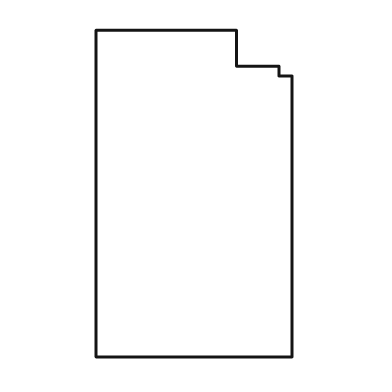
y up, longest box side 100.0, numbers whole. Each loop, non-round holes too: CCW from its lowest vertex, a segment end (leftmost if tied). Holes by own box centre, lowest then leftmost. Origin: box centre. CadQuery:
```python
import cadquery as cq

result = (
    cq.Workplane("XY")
    .moveTo(-30.0, -50.0)
    .lineTo(30.0, -50.0)
    .lineTo(30.0, 36.0)
    .lineTo(26.0, 36.0)
    .lineTo(26.0, 39.0)
    .lineTo(13.0, 39.0)
    .lineTo(13.0, 50.0)
    .lineTo(-30.0, 50.0)
    .close()
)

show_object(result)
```